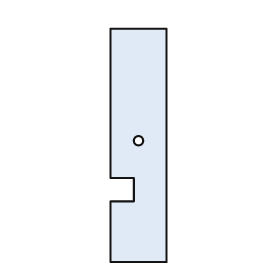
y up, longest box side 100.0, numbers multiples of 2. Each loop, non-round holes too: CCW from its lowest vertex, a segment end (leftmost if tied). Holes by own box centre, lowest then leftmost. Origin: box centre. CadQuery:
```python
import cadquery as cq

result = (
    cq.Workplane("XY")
    .moveTo(-12.0, -50.0)
    .lineTo(12.0, -50.0)
    .lineTo(12.0, 50.0)
    .lineTo(-12.0, 50.0)
    .lineTo(-12.0, -14.0)
    .lineTo(-2.0, -14.0)
    .lineTo(-2.0, -24.0)
    .lineTo(-12.0, -24.0)
    .close()
    .moveTo(0.0, 2.0)
    .circle(2.0)
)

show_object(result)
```